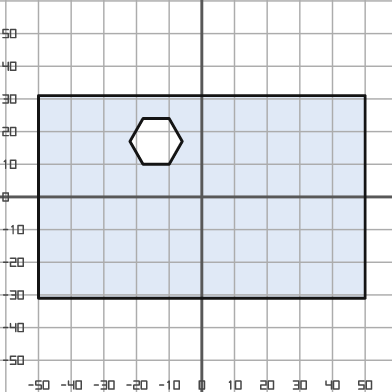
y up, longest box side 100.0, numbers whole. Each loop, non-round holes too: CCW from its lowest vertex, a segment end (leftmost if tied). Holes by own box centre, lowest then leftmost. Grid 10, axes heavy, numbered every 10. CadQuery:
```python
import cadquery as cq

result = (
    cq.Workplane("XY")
    .moveTo(-50.0, -31.0)
    .lineTo(50.0, -31.0)
    .lineTo(50.0, 31.0)
    .lineTo(-50.0, 31.0)
    .close()
    .moveTo(-18.0, 10.0)
    .lineTo(-10.0, 10.0)
    .lineTo(-6.0, 17.0)
    .lineTo(-10.0, 24.0)
    .lineTo(-18.0, 24.0)
    .lineTo(-22.0, 17.0)
    .close()
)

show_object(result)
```